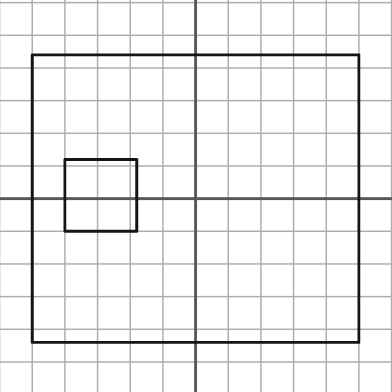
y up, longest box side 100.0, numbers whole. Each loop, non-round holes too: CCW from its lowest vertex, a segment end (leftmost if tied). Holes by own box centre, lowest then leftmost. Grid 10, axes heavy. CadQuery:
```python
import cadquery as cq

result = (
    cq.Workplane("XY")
    .moveTo(-50.0, -44.0)
    .lineTo(50.0, -44.0)
    .lineTo(50.0, 44.0)
    .lineTo(-50.0, 44.0)
    .close()
    .moveTo(-40.0, -10.0)
    .lineTo(-18.0, -10.0)
    .lineTo(-18.0, 12.0)
    .lineTo(-40.0, 12.0)
    .close()
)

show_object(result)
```